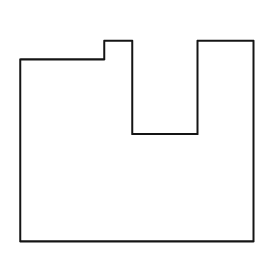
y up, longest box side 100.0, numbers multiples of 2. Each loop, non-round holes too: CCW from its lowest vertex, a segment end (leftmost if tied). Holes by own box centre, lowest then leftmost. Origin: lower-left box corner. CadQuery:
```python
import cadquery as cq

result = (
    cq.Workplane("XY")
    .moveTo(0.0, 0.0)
    .lineTo(100.0, 0.0)
    .lineTo(100.0, 86.0)
    .lineTo(76.0, 86.0)
    .lineTo(76.0, 46.0)
    .lineTo(48.0, 46.0)
    .lineTo(48.0, 86.0)
    .lineTo(36.0, 86.0)
    .lineTo(36.0, 78.0)
    .lineTo(0.0, 78.0)
    .close()
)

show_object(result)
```